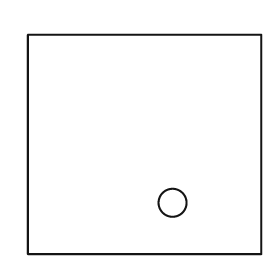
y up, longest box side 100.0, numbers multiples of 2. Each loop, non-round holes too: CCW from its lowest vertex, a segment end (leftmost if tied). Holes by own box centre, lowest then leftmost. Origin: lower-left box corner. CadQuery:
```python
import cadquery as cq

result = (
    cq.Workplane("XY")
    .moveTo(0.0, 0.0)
    .lineTo(100.0, 0.0)
    .lineTo(100.0, 94.0)
    .lineTo(0.0, 94.0)
    .close()
    .moveTo(62.0, 22.0)
    .circle(6.0)
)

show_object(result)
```